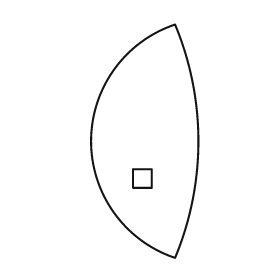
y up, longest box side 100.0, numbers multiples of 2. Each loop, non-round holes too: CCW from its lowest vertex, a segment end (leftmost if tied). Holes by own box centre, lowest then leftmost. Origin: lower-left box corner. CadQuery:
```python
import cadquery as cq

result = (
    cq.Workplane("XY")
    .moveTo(36.0, 0.0)
    .threePointArc((46.0, 50.0), (36.0, 100.0))
    .threePointArc((0.0, 50.0), (36.0, 0.0))
    .close()
    .moveTo(18.0, 30.0)
    .lineTo(26.0, 30.0)
    .lineTo(26.0, 38.0)
    .lineTo(18.0, 38.0)
    .close()
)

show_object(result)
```